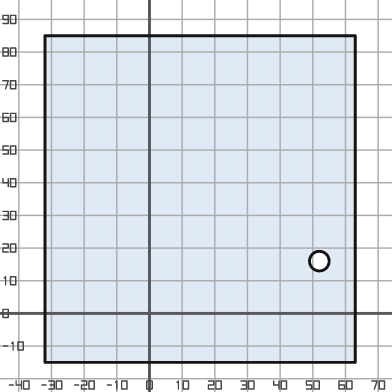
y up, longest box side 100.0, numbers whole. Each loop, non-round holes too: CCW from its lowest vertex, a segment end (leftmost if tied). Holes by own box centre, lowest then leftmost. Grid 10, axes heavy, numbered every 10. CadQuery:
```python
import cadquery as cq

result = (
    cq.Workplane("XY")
    .moveTo(-32.0, -15.0)
    .lineTo(63.0, -15.0)
    .lineTo(63.0, 85.0)
    .lineTo(-32.0, 85.0)
    .close()
    .moveTo(52.0, 16.0)
    .circle(3.0)
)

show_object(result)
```